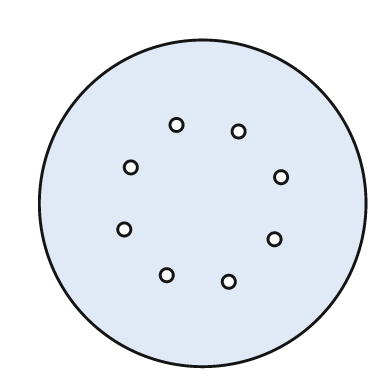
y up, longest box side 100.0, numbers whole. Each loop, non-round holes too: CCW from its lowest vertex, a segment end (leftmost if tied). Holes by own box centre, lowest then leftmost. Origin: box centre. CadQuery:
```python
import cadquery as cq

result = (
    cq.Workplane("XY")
    .moveTo(0.0, 0.0)
    .circle(50.0)
    .moveTo(8.0, -24.0)
    .circle(2.0)
    .moveTo(-11.0, -22.0)
    .circle(2.0)
    .moveTo(22.0, -11.0)
    .circle(2.0)
    .moveTo(-24.0, -8.0)
    .circle(2.0)
    .moveTo(24.0, 8.0)
    .circle(2.0)
    .moveTo(-22.0, 11.0)
    .circle(2.0)
    .moveTo(11.0, 22.0)
    .circle(2.0)
    .moveTo(-8.0, 24.0)
    .circle(2.0)
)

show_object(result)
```